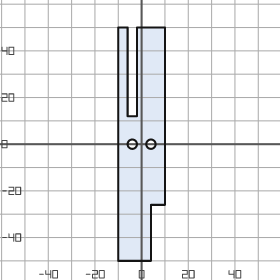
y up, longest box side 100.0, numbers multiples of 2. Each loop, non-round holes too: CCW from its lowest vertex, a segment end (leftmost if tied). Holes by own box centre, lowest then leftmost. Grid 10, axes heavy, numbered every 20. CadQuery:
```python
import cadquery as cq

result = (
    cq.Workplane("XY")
    .moveTo(-10.0, -50.0)
    .lineTo(4.0, -50.0)
    .lineTo(4.0, -26.0)
    .lineTo(10.0, -26.0)
    .lineTo(10.0, 50.0)
    .lineTo(-2.0, 50.0)
    .lineTo(-2.0, 12.0)
    .lineTo(-6.0, 12.0)
    .lineTo(-6.0, 50.0)
    .lineTo(-10.0, 50.0)
    .close()
    .moveTo(-4.0, 0.0)
    .circle(2.0)
    .moveTo(4.0, 0.0)
    .circle(2.0)
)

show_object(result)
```